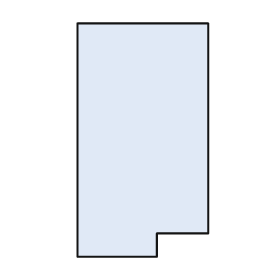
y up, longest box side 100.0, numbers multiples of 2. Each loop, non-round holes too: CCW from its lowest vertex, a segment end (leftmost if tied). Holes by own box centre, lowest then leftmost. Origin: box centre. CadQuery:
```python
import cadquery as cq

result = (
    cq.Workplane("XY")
    .moveTo(-28.0, -50.0)
    .lineTo(6.0, -50.0)
    .lineTo(6.0, -40.0)
    .lineTo(28.0, -40.0)
    .lineTo(28.0, 50.0)
    .lineTo(-28.0, 50.0)
    .close()
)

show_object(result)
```